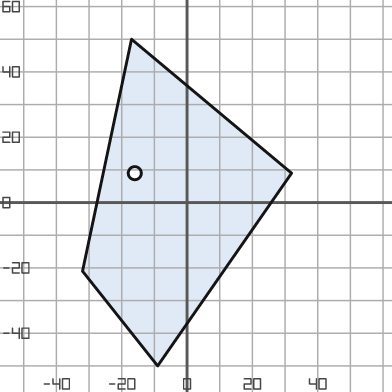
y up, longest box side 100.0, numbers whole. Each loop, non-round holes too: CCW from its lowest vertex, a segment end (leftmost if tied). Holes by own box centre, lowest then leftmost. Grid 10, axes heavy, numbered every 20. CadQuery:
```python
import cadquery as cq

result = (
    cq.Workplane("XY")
    .moveTo(-9.0, -50.0)
    .lineTo(32.0, 9.0)
    .lineTo(-17.0, 50.0)
    .lineTo(-32.0, -21.0)
    .close()
    .moveTo(-16.0, 9.0)
    .circle(2.0)
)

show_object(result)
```